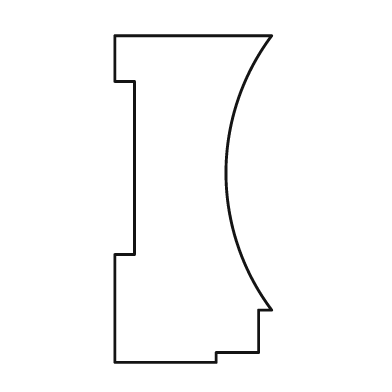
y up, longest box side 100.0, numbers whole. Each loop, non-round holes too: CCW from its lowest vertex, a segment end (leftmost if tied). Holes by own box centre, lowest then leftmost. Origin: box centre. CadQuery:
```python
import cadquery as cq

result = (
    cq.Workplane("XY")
    .moveTo(-24.0, -50.0)
    .lineTo(7.0, -50.0)
    .lineTo(7.0, -47.0)
    .lineTo(20.0, -47.0)
    .lineTo(20.0, -34.0)
    .lineTo(24.0, -34.0)
    .threePointArc((10.0, 8.0), (24.0, 50.0))
    .lineTo(-24.0, 50.0)
    .lineTo(-24.0, 36.0)
    .lineTo(-18.0, 36.0)
    .lineTo(-18.0, -17.0)
    .lineTo(-24.0, -17.0)
    .close()
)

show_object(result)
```